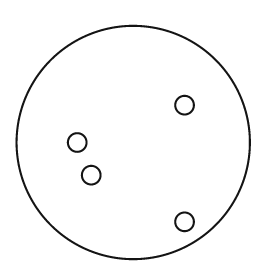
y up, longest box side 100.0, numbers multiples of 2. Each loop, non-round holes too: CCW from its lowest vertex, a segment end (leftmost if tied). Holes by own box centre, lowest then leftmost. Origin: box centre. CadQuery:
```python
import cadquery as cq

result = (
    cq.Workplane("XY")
    .moveTo(0.0, 0.0)
    .circle(50.0)
    .moveTo(22.0, -34.0)
    .circle(4.0)
    .moveTo(-18.0, -14.0)
    .circle(4.0)
    .moveTo(-24.0, 0.0)
    .circle(4.0)
    .moveTo(22.0, 16.0)
    .circle(4.0)
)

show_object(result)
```